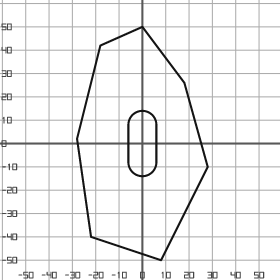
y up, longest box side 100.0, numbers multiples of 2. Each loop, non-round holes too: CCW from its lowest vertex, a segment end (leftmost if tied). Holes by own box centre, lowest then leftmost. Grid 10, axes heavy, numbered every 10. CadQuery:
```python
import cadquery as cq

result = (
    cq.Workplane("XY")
    .moveTo(8.0, -50.0)
    .lineTo(28.0, -10.0)
    .lineTo(18.0, 26.0)
    .lineTo(0.0, 50.0)
    .lineTo(-18.0, 42.0)
    .lineTo(-28.0, 2.0)
    .lineTo(-22.0, -40.0)
    .close()
    .moveTo(-6.0, -8.0)
    .threePointArc((0.0, -14.0), (6.0, -8.0))
    .lineTo(6.0, 8.0)
    .threePointArc((0.0, 14.0), (-6.0, 8.0))
    .close()
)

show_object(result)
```